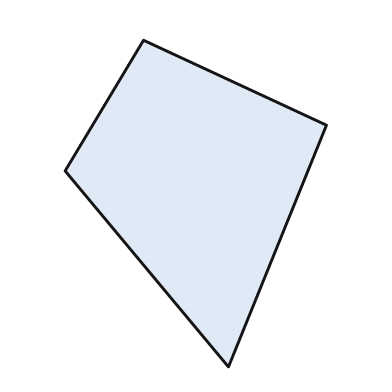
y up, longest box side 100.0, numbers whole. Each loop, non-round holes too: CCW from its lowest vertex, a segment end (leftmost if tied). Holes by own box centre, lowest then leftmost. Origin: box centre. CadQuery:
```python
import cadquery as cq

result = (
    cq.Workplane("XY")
    .moveTo(10.0, -50.0)
    .lineTo(40.0, 24.0)
    .lineTo(-16.0, 50.0)
    .lineTo(-40.0, 10.0)
    .close()
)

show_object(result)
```